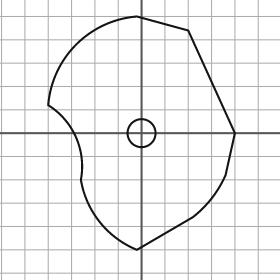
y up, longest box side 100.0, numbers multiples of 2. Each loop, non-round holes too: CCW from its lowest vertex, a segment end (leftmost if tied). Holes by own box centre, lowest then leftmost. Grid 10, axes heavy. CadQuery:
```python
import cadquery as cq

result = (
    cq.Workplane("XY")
    .moveTo(-2.0, -50.0)
    .lineTo(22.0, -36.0)
    .threePointArc((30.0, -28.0), (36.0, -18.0))
    .lineTo(40.0, 0.0)
    .lineTo(20.0, 44.0)
    .lineTo(-2.0, 50.0)
    .threePointArc((-28.0, 38.0), (-40.0, 12.0))
    .threePointArc((-28.0, -2.0), (-26.0, -20.0))
    .threePointArc((-18.0, -38.0), (-2.0, -50.0))
    .close()
    .moveTo(0.0, 0.0)
    .circle(6.0)
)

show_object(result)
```